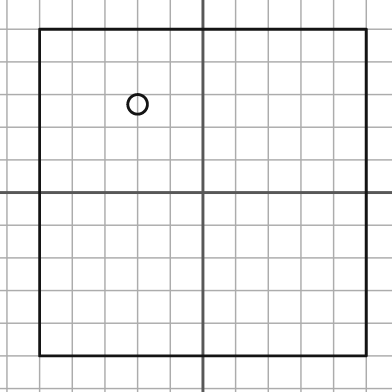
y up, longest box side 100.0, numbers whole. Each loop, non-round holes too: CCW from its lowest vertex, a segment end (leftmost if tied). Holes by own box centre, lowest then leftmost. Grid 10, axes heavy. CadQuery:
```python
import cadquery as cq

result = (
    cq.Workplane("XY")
    .moveTo(-50.0, -50.0)
    .lineTo(50.0, -50.0)
    .lineTo(50.0, 50.0)
    .lineTo(-50.0, 50.0)
    .close()
    .moveTo(-20.0, 27.0)
    .circle(3.0)
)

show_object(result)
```